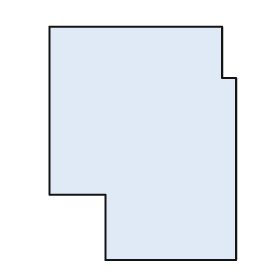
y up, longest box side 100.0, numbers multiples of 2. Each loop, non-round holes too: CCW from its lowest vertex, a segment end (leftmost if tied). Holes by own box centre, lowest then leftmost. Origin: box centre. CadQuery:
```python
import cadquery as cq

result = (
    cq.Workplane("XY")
    .moveTo(-16.0, -50.0)
    .lineTo(40.0, -50.0)
    .lineTo(40.0, 28.0)
    .lineTo(34.0, 28.0)
    .lineTo(34.0, 50.0)
    .lineTo(-40.0, 50.0)
    .lineTo(-40.0, -22.0)
    .lineTo(-16.0, -22.0)
    .close()
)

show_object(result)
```